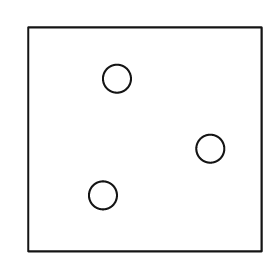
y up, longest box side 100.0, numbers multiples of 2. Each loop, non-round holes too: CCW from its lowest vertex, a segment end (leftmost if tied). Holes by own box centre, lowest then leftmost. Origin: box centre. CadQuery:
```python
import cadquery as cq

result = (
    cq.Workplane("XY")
    .moveTo(-50.0, -48.0)
    .lineTo(50.0, -48.0)
    .lineTo(50.0, 48.0)
    .lineTo(-50.0, 48.0)
    .close()
    .moveTo(-18.0, -24.0)
    .circle(6.0)
    .moveTo(28.0, -4.0)
    .circle(6.0)
    .moveTo(-12.0, 26.0)
    .circle(6.0)
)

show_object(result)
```